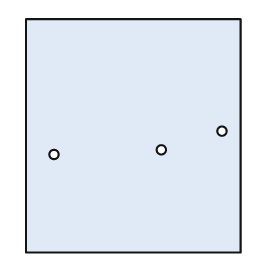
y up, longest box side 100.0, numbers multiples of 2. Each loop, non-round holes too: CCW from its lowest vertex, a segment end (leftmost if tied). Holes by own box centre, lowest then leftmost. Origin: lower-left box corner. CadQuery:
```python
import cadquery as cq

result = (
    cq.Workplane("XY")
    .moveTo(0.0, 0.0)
    .lineTo(92.0, 0.0)
    .lineTo(92.0, 100.0)
    .lineTo(0.0, 100.0)
    .close()
    .moveTo(12.0, 42.0)
    .circle(2.0)
    .moveTo(58.0, 44.0)
    .circle(2.0)
    .moveTo(84.0, 52.0)
    .circle(2.0)
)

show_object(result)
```